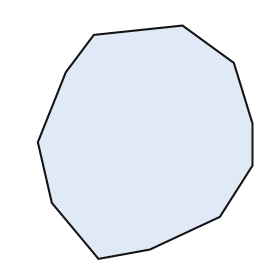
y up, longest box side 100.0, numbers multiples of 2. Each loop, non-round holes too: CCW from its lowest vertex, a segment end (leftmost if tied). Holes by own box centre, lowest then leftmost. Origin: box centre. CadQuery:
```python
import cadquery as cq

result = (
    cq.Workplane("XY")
    .moveTo(-20.0, -50.0)
    .lineTo(2.0, -46.0)
    .lineTo(32.0, -32.0)
    .lineTo(46.0, -10.0)
    .lineTo(46.0, 8.0)
    .lineTo(38.0, 34.0)
    .lineTo(16.0, 50.0)
    .lineTo(-22.0, 46.0)
    .lineTo(-34.0, 30.0)
    .lineTo(-46.0, 0.0)
    .lineTo(-40.0, -26.0)
    .close()
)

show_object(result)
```